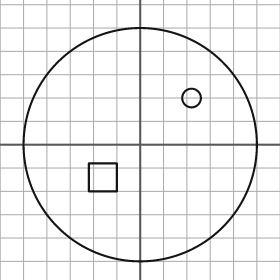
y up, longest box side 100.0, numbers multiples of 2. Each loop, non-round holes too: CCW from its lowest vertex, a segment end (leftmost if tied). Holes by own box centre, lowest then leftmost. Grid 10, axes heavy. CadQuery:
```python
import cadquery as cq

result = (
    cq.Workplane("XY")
    .moveTo(0.0, 0.0)
    .circle(50.0)
    .moveTo(-22.0, -20.0)
    .lineTo(-10.0, -20.0)
    .lineTo(-10.0, -8.0)
    .lineTo(-22.0, -8.0)
    .close()
    .moveTo(22.0, 20.0)
    .circle(4.0)
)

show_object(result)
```